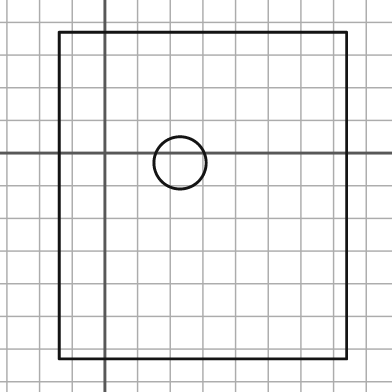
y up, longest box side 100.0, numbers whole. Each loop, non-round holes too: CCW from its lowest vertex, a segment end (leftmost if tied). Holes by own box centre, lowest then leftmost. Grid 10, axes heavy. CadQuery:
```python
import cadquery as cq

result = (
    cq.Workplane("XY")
    .moveTo(-14.0, -63.0)
    .lineTo(74.0, -63.0)
    .lineTo(74.0, 37.0)
    .lineTo(-14.0, 37.0)
    .close()
    .moveTo(23.0, -3.0)
    .circle(8.0)
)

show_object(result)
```